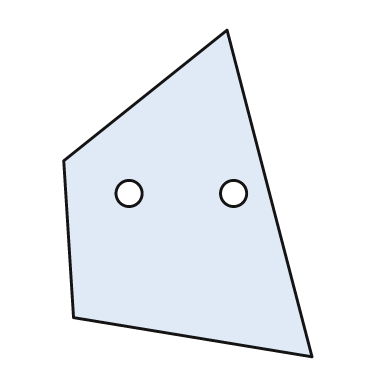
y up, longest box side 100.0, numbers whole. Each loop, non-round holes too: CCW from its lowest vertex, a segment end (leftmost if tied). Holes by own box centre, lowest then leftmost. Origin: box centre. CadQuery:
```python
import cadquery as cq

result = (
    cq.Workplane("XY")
    .moveTo(38.0, -50.0)
    .lineTo(12.0, 50.0)
    .lineTo(-38.0, 10.0)
    .lineTo(-35.0, -38.0)
    .close()
    .moveTo(-18.0, 0.0)
    .circle(4.0)
    .moveTo(14.0, 0.0)
    .circle(4.0)
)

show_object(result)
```